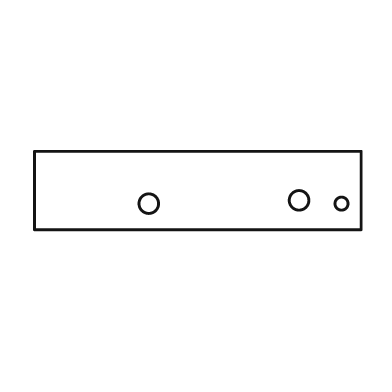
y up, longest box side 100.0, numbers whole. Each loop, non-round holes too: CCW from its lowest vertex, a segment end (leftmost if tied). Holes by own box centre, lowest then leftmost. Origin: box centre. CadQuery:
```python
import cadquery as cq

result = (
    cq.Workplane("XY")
    .moveTo(-50.0, -12.0)
    .lineTo(50.0, -12.0)
    .lineTo(50.0, 12.0)
    .lineTo(-50.0, 12.0)
    .close()
    .moveTo(-15.0, -4.0)
    .circle(3.0)
    .moveTo(44.0, -4.0)
    .circle(2.0)
    .moveTo(31.0, -3.0)
    .circle(3.0)
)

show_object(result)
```